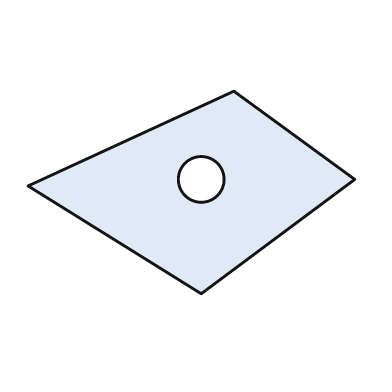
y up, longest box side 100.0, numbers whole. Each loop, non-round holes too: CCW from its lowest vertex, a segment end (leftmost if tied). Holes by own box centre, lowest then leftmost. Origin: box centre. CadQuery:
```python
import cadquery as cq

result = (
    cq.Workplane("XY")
    .moveTo(3.0, -31.0)
    .lineTo(50.0, 4.0)
    .lineTo(13.0, 31.0)
    .lineTo(-50.0, 2.0)
    .close()
    .moveTo(3.0, 4.0)
    .circle(7.0)
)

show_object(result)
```